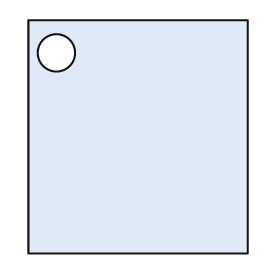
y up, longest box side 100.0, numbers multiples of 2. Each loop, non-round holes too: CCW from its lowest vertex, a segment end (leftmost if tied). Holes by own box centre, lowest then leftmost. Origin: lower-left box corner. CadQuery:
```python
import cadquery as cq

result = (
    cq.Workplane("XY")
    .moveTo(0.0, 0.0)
    .lineTo(94.0, 0.0)
    .lineTo(94.0, 100.0)
    .lineTo(0.0, 100.0)
    .close()
    .moveTo(12.0, 86.0)
    .circle(8.0)
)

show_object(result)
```